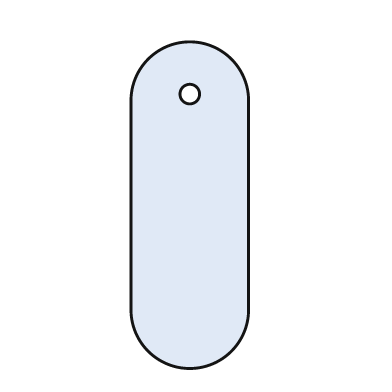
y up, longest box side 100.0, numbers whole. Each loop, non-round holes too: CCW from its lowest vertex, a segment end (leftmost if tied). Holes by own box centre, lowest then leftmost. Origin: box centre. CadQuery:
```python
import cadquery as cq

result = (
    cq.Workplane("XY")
    .moveTo(-18.0, -32.0)
    .threePointArc((0.0, -50.0), (18.0, -32.0))
    .lineTo(18.0, 32.0)
    .threePointArc((0.0, 50.0), (-18.0, 32.0))
    .close()
    .moveTo(0.0, 34.0)
    .circle(3.0)
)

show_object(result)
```